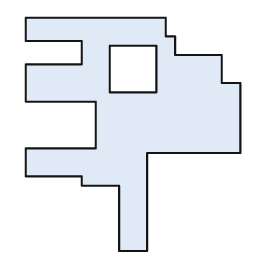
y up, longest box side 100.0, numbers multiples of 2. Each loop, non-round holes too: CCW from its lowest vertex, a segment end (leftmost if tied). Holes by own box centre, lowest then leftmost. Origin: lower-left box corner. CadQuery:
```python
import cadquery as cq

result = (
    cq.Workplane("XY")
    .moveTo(40.0, 0.0)
    .lineTo(52.0, 0.0)
    .lineTo(52.0, 42.0)
    .lineTo(92.0, 42.0)
    .lineTo(92.0, 72.0)
    .lineTo(84.0, 72.0)
    .lineTo(84.0, 84.0)
    .lineTo(64.0, 84.0)
    .lineTo(64.0, 92.0)
    .lineTo(60.0, 92.0)
    .lineTo(60.0, 100.0)
    .lineTo(0.0, 100.0)
    .lineTo(0.0, 90.0)
    .lineTo(24.0, 90.0)
    .lineTo(24.0, 80.0)
    .lineTo(0.0, 80.0)
    .lineTo(0.0, 64.0)
    .lineTo(30.0, 64.0)
    .lineTo(30.0, 44.0)
    .lineTo(0.0, 44.0)
    .lineTo(0.0, 32.0)
    .lineTo(24.0, 32.0)
    .lineTo(24.0, 28.0)
    .lineTo(40.0, 28.0)
    .close()
    .moveTo(36.0, 68.0)
    .lineTo(56.0, 68.0)
    .lineTo(56.0, 88.0)
    .lineTo(36.0, 88.0)
    .close()
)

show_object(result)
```